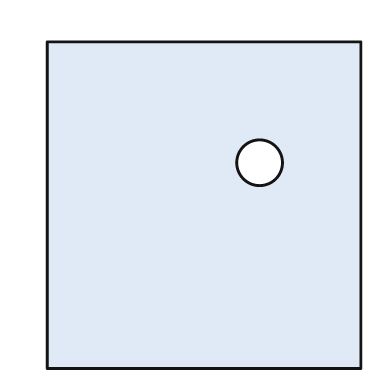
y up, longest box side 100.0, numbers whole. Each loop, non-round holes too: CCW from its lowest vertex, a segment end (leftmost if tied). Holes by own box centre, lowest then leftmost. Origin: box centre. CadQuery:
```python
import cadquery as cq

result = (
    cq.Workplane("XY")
    .moveTo(-48.0, -50.0)
    .lineTo(48.0, -50.0)
    .lineTo(48.0, 50.0)
    .lineTo(-48.0, 50.0)
    .close()
    .moveTo(17.0, 13.0)
    .circle(7.0)
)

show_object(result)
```